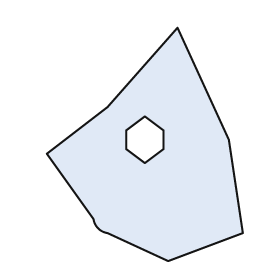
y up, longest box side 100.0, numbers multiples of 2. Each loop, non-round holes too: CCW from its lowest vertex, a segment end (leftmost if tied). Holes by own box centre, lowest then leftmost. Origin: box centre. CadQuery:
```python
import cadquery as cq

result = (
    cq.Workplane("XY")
    .moveTo(10.0, -50.0)
    .lineTo(42.0, -38.0)
    .lineTo(36.0, 2.0)
    .lineTo(14.0, 50.0)
    .lineTo(-16.0, 16.0)
    .lineTo(-42.0, -4.0)
    .lineTo(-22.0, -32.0)
    .threePointArc((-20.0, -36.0), (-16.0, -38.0))
    .close()
    .moveTo(0.0, -8.0)
    .lineTo(8.0, -2.0)
    .lineTo(8.0, 6.0)
    .lineTo(0.0, 12.0)
    .lineTo(-8.0, 6.0)
    .lineTo(-8.0, -2.0)
    .close()
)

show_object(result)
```